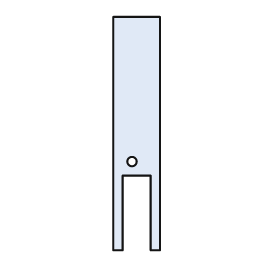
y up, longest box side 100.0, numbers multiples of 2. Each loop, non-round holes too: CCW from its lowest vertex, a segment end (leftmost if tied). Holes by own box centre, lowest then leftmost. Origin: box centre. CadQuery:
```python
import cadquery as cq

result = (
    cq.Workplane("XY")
    .moveTo(-10.0, -50.0)
    .lineTo(-6.0, -50.0)
    .lineTo(-6.0, -18.0)
    .lineTo(6.0, -18.0)
    .lineTo(6.0, -50.0)
    .lineTo(10.0, -50.0)
    .lineTo(10.0, 50.0)
    .lineTo(-10.0, 50.0)
    .close()
    .moveTo(-2.0, -12.0)
    .circle(2.0)
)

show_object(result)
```